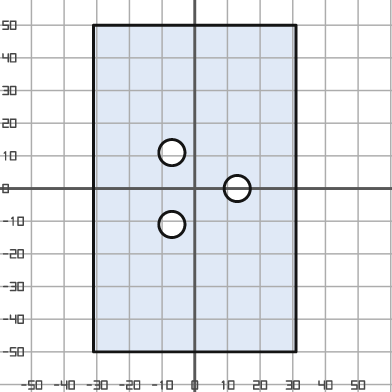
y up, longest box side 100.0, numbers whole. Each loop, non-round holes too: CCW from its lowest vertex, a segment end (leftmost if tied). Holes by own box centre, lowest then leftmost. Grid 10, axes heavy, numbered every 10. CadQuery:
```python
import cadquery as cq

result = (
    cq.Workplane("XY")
    .moveTo(-31.0, -50.0)
    .lineTo(31.0, -50.0)
    .lineTo(31.0, 50.0)
    .lineTo(-31.0, 50.0)
    .close()
    .moveTo(-7.0, -11.0)
    .circle(4.0)
    .moveTo(13.0, 0.0)
    .circle(4.0)
    .moveTo(-7.0, 11.0)
    .circle(4.0)
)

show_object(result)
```